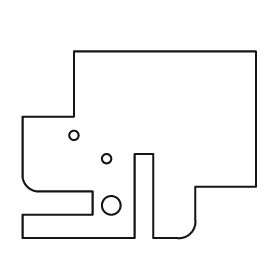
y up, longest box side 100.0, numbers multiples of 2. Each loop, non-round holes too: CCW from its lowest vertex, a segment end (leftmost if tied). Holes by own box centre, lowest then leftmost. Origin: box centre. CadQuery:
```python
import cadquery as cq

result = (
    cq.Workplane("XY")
    .moveTo(-50.0, -40.0)
    .lineTo(-2.0, -40.0)
    .lineTo(-2.0, -4.0)
    .lineTo(6.0, -4.0)
    .lineTo(6.0, -40.0)
    .lineTo(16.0, -40.0)
    .threePointArc((22.0, -38.0), (24.0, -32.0))
    .lineTo(24.0, -18.0)
    .lineTo(50.0, -18.0)
    .lineTo(50.0, 40.0)
    .lineTo(-28.0, 40.0)
    .lineTo(-28.0, 12.0)
    .lineTo(-50.0, 12.0)
    .lineTo(-50.0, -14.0)
    .threePointArc((-48.0, -18.0), (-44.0, -20.0))
    .lineTo(-20.0, -20.0)
    .lineTo(-20.0, -30.0)
    .lineTo(-50.0, -30.0)
    .close()
    .moveTo(-12.0, -26.0)
    .circle(4.0)
    .moveTo(-14.0, -6.0)
    .circle(2.0)
    .moveTo(-28.0, 4.0)
    .circle(2.0)
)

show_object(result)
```